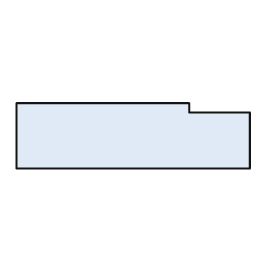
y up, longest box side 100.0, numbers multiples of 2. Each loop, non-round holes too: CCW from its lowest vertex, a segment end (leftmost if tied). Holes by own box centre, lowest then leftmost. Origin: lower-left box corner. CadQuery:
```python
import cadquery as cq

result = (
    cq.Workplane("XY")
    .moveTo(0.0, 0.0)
    .lineTo(100.0, 0.0)
    .lineTo(100.0, 24.0)
    .lineTo(74.0, 24.0)
    .lineTo(74.0, 28.0)
    .lineTo(0.0, 28.0)
    .close()
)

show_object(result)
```